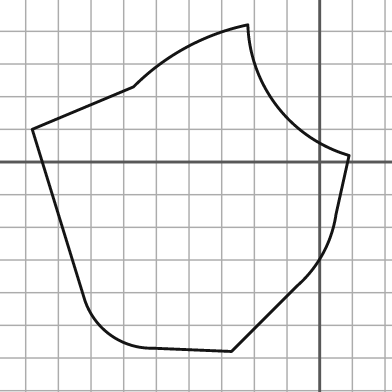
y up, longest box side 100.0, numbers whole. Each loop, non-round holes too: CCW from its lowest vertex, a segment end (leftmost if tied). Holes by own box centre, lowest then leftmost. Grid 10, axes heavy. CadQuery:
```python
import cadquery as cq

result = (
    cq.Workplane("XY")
    .moveTo(-27.0, -58.0)
    .lineTo(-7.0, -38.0)
    .threePointArc((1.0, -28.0), (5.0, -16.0))
    .lineTo(9.0, 2.0)
    .threePointArc((-13.0, 17.0), (-22.0, 42.0))
    .threePointArc((-41.0, 35.0), (-57.0, 23.0))
    .lineTo(-88.0, 10.0)
    .lineTo(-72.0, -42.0)
    .threePointArc((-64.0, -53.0), (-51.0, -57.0))
    .close()
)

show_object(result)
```